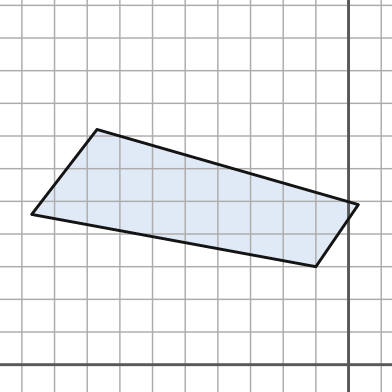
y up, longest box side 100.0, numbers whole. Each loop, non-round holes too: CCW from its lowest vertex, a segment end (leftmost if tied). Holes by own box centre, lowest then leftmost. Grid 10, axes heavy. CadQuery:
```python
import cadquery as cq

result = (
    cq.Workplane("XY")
    .moveTo(-10.0, 30.0)
    .lineTo(3.0, 49.0)
    .lineTo(-77.0, 72.0)
    .lineTo(-97.0, 46.0)
    .close()
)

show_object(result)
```